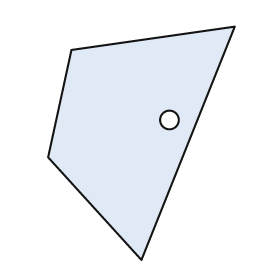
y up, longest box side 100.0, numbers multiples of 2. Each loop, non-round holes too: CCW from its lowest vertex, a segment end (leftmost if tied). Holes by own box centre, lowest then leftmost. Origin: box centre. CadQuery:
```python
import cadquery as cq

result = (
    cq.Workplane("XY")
    .moveTo(0.0, -50.0)
    .lineTo(40.0, 50.0)
    .lineTo(-30.0, 40.0)
    .lineTo(-40.0, -6.0)
    .close()
    .moveTo(12.0, 10.0)
    .circle(4.0)
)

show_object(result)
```